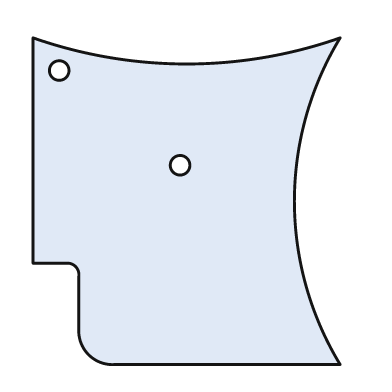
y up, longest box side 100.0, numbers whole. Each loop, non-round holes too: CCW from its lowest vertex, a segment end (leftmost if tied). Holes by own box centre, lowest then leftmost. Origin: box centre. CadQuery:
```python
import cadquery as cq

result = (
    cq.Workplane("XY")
    .moveTo(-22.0, -50.0)
    .lineTo(47.0, -50.0)
    .threePointArc((33.0, 0.0), (47.0, 50.0))
    .threePointArc((0.0, 42.0), (-47.0, 50.0))
    .lineTo(-47.0, -19.0)
    .lineTo(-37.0, -19.0)
    .threePointArc((-34.0, -20.0), (-33.0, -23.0))
    .lineTo(-33.0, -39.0)
    .threePointArc((-30.0, -47.0), (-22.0, -50.0))
    .close()
    .moveTo(-2.0, 11.0)
    .circle(3.0)
    .moveTo(-39.0, 40.0)
    .circle(3.0)
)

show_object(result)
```